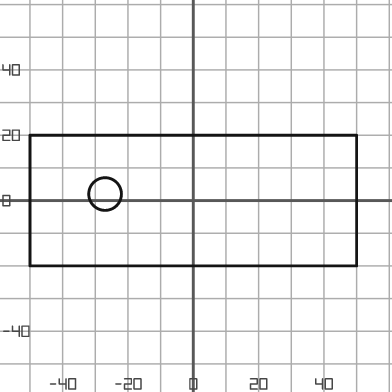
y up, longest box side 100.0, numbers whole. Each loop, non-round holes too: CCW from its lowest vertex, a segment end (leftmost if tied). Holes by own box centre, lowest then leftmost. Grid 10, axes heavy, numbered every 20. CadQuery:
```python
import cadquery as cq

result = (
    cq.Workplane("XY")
    .moveTo(-50.0, -20.0)
    .lineTo(50.0, -20.0)
    .lineTo(50.0, 20.0)
    .lineTo(-50.0, 20.0)
    .close()
    .moveTo(-27.0, 2.0)
    .circle(5.0)
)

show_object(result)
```